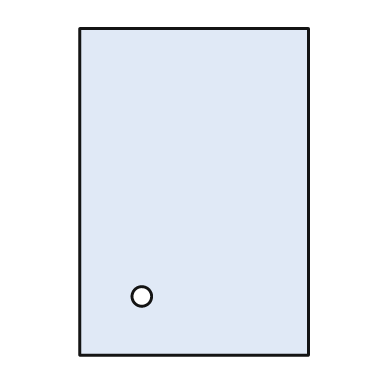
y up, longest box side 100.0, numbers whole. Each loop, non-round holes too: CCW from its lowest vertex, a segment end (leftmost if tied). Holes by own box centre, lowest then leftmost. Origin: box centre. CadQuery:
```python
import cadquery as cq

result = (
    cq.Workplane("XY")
    .moveTo(-35.0, -50.0)
    .lineTo(35.0, -50.0)
    .lineTo(35.0, 50.0)
    .lineTo(-35.0, 50.0)
    .close()
    .moveTo(-16.0, -32.0)
    .circle(3.0)
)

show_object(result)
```